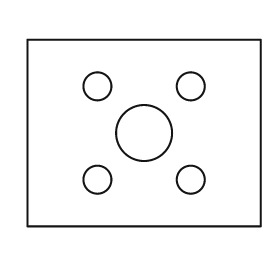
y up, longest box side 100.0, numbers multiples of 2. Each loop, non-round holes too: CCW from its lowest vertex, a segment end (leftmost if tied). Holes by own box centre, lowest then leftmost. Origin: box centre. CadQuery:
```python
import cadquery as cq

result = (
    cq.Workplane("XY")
    .moveTo(-50.0, -40.0)
    .lineTo(50.0, -40.0)
    .lineTo(50.0, 40.0)
    .lineTo(-50.0, 40.0)
    .close()
    .moveTo(-20.0, -20.0)
    .circle(6.0)
    .moveTo(20.0, -20.0)
    .circle(6.0)
    .moveTo(0.0, 0.0)
    .circle(12.0)
    .moveTo(-20.0, 20.0)
    .circle(6.0)
    .moveTo(20.0, 20.0)
    .circle(6.0)
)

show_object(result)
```